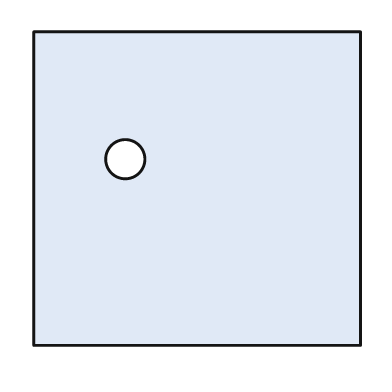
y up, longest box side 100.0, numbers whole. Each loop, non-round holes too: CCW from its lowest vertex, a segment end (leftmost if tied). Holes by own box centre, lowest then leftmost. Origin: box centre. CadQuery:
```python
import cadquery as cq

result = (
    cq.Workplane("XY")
    .moveTo(-50.0, -48.0)
    .lineTo(50.0, -48.0)
    .lineTo(50.0, 48.0)
    .lineTo(-50.0, 48.0)
    .close()
    .moveTo(-22.0, 9.0)
    .circle(6.0)
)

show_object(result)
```